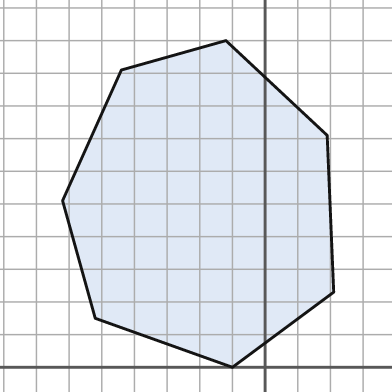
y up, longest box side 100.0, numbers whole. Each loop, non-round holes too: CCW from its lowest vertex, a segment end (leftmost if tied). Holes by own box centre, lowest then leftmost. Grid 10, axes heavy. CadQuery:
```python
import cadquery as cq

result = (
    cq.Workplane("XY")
    .moveTo(-10.0, 0.0)
    .lineTo(21.0, 23.0)
    .lineTo(19.0, 71.0)
    .lineTo(-12.0, 100.0)
    .lineTo(-44.0, 91.0)
    .lineTo(-62.0, 51.0)
    .lineTo(-52.0, 15.0)
    .close()
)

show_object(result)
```